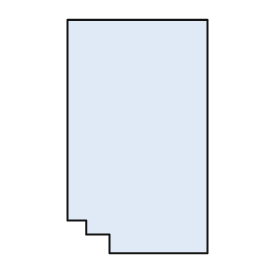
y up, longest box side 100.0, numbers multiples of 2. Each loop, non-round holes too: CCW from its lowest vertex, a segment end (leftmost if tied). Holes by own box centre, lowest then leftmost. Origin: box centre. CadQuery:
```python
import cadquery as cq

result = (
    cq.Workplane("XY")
    .moveTo(-12.0, -50.0)
    .lineTo(30.0, -50.0)
    .lineTo(30.0, 50.0)
    .lineTo(-30.0, 50.0)
    .lineTo(-30.0, -36.0)
    .lineTo(-22.0, -36.0)
    .lineTo(-22.0, -42.0)
    .lineTo(-12.0, -42.0)
    .close()
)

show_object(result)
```